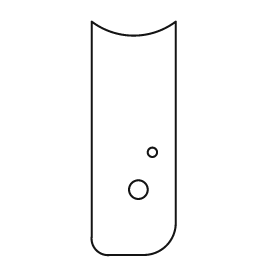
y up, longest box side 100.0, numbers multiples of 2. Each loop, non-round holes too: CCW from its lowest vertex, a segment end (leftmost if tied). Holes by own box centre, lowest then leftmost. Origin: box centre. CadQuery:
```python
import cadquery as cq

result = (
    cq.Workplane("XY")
    .moveTo(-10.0, -50.0)
    .lineTo(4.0, -50.0)
    .threePointArc((14.0, -46.0), (18.0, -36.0))
    .lineTo(18.0, 50.0)
    .threePointArc((0.0, 44.0), (-18.0, 50.0))
    .lineTo(-18.0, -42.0)
    .threePointArc((-16.0, -48.0), (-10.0, -50.0))
    .close()
    .moveTo(2.0, -22.0)
    .circle(4.0)
    .moveTo(8.0, -6.0)
    .circle(2.0)
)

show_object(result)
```